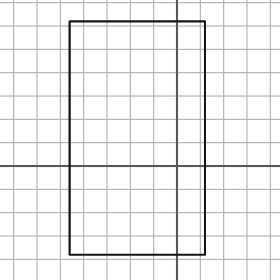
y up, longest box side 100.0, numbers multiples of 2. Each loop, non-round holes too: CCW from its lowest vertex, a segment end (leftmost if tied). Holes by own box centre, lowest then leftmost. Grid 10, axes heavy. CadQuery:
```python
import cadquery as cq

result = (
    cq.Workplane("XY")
    .moveTo(-46.0, -38.0)
    .lineTo(12.0, -38.0)
    .lineTo(12.0, 62.0)
    .lineTo(-46.0, 62.0)
    .close()
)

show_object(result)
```